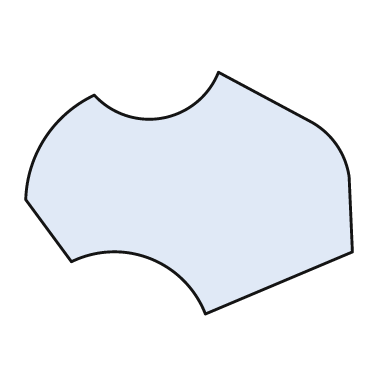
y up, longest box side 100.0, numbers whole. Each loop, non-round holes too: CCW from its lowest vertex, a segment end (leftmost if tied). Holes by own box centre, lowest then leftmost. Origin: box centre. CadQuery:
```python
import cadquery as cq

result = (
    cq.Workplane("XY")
    .moveTo(5.0, -37.0)
    .lineTo(50.0, -18.0)
    .lineTo(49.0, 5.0)
    .threePointArc((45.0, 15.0), (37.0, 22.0))
    .lineTo(9.0, 37.0)
    .threePointArc((-8.0, 23.0), (-29.0, 30.0))
    .threePointArc((-44.0, 17.0), (-50.0, -2.0))
    .lineTo(-36.0, -21.0)
    .threePointArc((-12.0, -20.0), (5.0, -37.0))
    .close()
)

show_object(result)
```